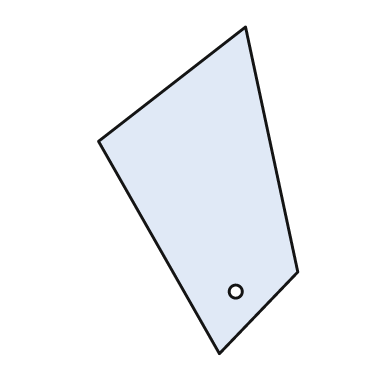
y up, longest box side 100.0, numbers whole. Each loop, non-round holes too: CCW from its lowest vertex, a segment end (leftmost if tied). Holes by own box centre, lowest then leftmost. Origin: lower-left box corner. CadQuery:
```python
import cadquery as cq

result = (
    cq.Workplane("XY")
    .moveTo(37.0, 0.0)
    .lineTo(61.0, 25.0)
    .lineTo(45.0, 100.0)
    .lineTo(0.0, 65.0)
    .close()
    .moveTo(42.0, 19.0)
    .circle(2.0)
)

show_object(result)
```